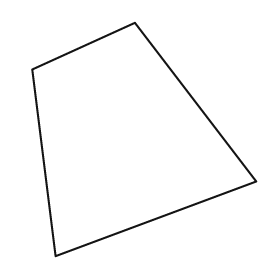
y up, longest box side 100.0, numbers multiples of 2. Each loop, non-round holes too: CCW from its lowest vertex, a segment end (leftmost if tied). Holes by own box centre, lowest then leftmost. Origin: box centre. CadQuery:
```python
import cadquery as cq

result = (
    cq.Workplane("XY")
    .moveTo(-38.0, -50.0)
    .lineTo(48.0, -18.0)
    .lineTo(-4.0, 50.0)
    .lineTo(-48.0, 30.0)
    .close()
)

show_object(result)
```